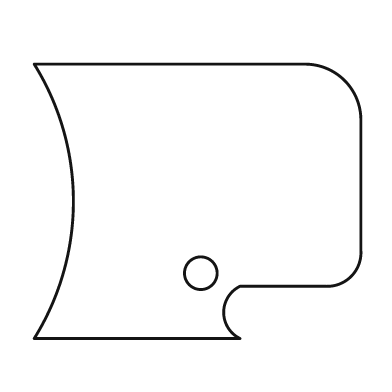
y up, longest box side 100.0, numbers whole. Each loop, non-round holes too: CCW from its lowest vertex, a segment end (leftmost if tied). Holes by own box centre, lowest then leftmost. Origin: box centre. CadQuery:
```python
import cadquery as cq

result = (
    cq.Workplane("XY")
    .moveTo(-50.0, -42.0)
    .lineTo(13.0, -42.0)
    .threePointArc((8.0, -34.0), (13.0, -26.0))
    .lineTo(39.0, -26.0)
    .threePointArc((47.0, -23.0), (50.0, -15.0))
    .lineTo(50.0, 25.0)
    .threePointArc((45.0, 37.0), (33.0, 42.0))
    .lineTo(-50.0, 42.0)
    .threePointArc((-38.0, 0.0), (-50.0, -42.0))
    .close()
    .moveTo(1.0, -22.0)
    .circle(5.0)
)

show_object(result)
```